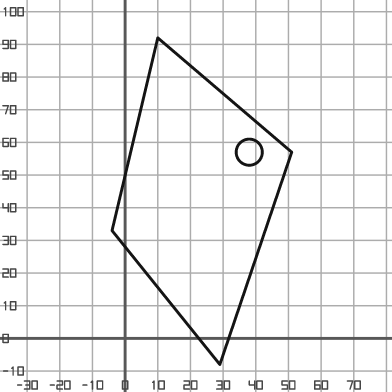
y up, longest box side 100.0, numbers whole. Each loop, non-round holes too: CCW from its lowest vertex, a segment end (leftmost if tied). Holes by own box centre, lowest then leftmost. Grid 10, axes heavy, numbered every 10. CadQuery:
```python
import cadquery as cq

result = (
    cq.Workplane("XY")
    .moveTo(29.0, -8.0)
    .lineTo(51.0, 57.0)
    .lineTo(10.0, 92.0)
    .lineTo(-4.0, 33.0)
    .close()
    .moveTo(38.0, 57.0)
    .circle(4.0)
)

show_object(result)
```